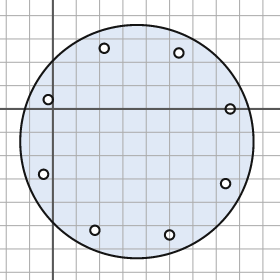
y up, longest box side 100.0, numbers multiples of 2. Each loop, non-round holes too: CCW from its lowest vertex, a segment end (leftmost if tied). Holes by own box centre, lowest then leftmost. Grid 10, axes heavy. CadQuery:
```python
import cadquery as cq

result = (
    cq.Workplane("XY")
    .moveTo(36.0, -14.0)
    .circle(50.0)
    .moveTo(50.0, -54.0)
    .circle(2.0)
    .moveTo(18.0, -52.0)
    .circle(2.0)
    .moveTo(74.0, -32.0)
    .circle(2.0)
    .moveTo(-4.0, -28.0)
    .circle(2.0)
    .moveTo(76.0, 0.0)
    .circle(2.0)
    .moveTo(-2.0, 4.0)
    .circle(2.0)
    .moveTo(54.0, 24.0)
    .circle(2.0)
    .moveTo(22.0, 26.0)
    .circle(2.0)
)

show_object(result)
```